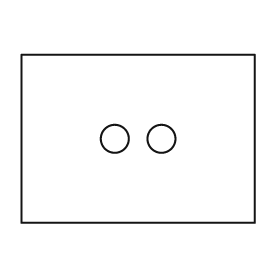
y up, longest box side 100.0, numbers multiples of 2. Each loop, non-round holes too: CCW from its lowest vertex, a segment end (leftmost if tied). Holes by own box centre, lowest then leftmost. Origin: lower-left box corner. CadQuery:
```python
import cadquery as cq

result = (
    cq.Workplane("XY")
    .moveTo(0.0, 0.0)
    .lineTo(100.0, 0.0)
    .lineTo(100.0, 72.0)
    .lineTo(0.0, 72.0)
    .close()
    .moveTo(40.0, 36.0)
    .circle(6.0)
    .moveTo(60.0, 36.0)
    .circle(6.0)
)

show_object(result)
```